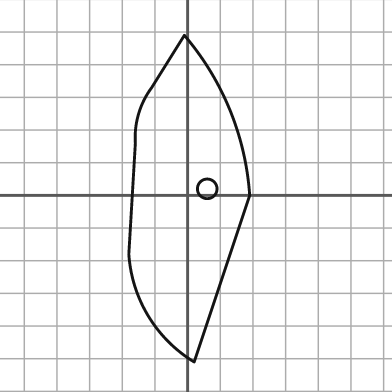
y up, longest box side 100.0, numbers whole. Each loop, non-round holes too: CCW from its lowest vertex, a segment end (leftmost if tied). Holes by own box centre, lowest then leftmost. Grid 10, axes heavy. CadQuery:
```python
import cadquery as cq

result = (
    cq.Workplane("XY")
    .moveTo(2.0, -51.0)
    .lineTo(19.0, 0.0)
    .threePointArc((13.0, 26.0), (-1.0, 49.0))
    .lineTo(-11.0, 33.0)
    .threePointArc((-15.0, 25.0), (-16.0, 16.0))
    .lineTo(-18.0, -18.0)
    .threePointArc((-12.0, -37.0), (2.0, -51.0))
    .close()
    .moveTo(6.0, 2.0)
    .circle(3.0)
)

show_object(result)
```